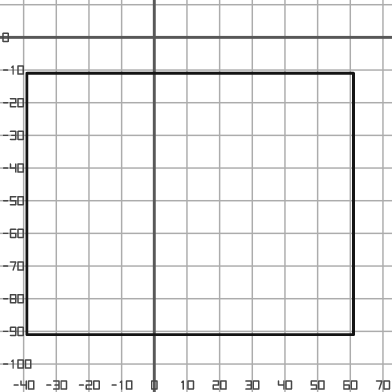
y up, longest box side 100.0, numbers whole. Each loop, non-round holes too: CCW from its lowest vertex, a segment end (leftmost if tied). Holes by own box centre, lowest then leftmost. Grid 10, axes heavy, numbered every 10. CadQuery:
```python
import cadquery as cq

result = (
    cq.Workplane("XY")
    .moveTo(-39.0, -91.0)
    .lineTo(61.0, -91.0)
    .lineTo(61.0, -11.0)
    .lineTo(-39.0, -11.0)
    .close()
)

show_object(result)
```